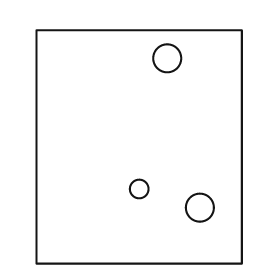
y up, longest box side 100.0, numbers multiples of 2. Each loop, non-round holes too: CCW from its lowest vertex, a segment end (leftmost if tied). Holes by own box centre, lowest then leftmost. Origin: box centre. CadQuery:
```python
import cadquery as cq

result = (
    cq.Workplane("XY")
    .moveTo(-44.0, -50.0)
    .lineTo(44.0, -50.0)
    .lineTo(44.0, 50.0)
    .lineTo(-44.0, 50.0)
    .close()
    .moveTo(26.0, -26.0)
    .circle(6.0)
    .moveTo(0.0, -18.0)
    .circle(4.0)
    .moveTo(12.0, 38.0)
    .circle(6.0)
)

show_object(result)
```